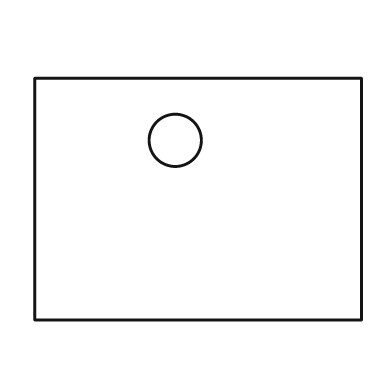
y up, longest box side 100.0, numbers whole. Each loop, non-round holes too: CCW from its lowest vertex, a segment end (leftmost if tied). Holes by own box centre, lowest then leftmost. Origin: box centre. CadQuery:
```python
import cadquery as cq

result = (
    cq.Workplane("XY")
    .moveTo(-50.0, -37.0)
    .lineTo(50.0, -37.0)
    .lineTo(50.0, 37.0)
    .lineTo(-50.0, 37.0)
    .close()
    .moveTo(-7.0, 18.0)
    .circle(8.0)
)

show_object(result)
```